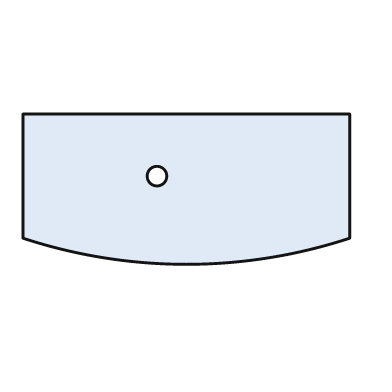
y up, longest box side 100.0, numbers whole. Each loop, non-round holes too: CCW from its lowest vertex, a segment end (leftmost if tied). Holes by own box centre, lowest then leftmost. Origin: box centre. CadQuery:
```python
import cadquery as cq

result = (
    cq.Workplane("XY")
    .moveTo(-50.0, -15.0)
    .threePointArc((0.0, -23.0), (50.0, -15.0))
    .lineTo(50.0, 23.0)
    .lineTo(-50.0, 23.0)
    .close()
    .moveTo(-9.0, 4.0)
    .circle(3.0)
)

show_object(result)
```